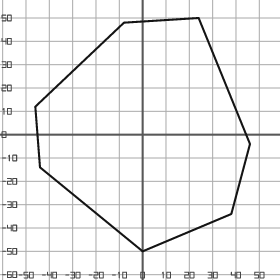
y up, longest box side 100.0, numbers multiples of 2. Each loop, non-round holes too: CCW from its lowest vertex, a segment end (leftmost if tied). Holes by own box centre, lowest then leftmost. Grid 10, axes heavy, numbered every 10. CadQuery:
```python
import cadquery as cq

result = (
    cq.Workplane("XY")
    .moveTo(0.0, -50.0)
    .lineTo(38.0, -34.0)
    .lineTo(46.0, -4.0)
    .lineTo(24.0, 50.0)
    .lineTo(-8.0, 48.0)
    .lineTo(-46.0, 12.0)
    .lineTo(-44.0, -14.0)
    .close()
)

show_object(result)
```